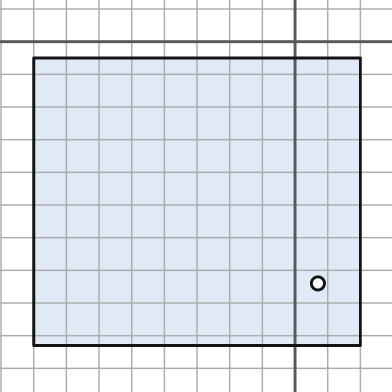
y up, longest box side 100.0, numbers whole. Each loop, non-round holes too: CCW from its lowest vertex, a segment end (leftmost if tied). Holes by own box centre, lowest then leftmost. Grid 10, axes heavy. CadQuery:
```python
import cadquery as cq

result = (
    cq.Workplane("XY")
    .moveTo(-80.0, -93.0)
    .lineTo(20.0, -93.0)
    .lineTo(20.0, -5.0)
    .lineTo(-80.0, -5.0)
    .close()
    .moveTo(7.0, -74.0)
    .circle(2.0)
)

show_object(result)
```